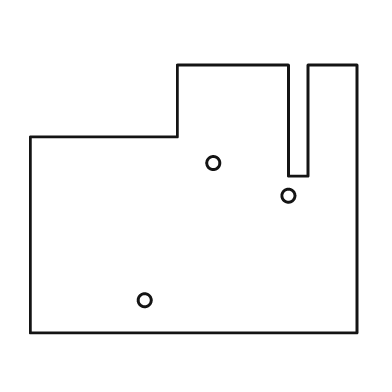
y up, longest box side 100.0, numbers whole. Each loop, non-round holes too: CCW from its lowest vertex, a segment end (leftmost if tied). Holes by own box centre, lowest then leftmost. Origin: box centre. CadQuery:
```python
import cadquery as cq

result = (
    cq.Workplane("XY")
    .moveTo(-50.0, -41.0)
    .lineTo(50.0, -41.0)
    .lineTo(50.0, 41.0)
    .lineTo(35.0, 41.0)
    .lineTo(35.0, 7.0)
    .lineTo(29.0, 7.0)
    .lineTo(29.0, 41.0)
    .lineTo(-5.0, 41.0)
    .lineTo(-5.0, 19.0)
    .lineTo(-50.0, 19.0)
    .close()
    .moveTo(-15.0, -31.0)
    .circle(2.0)
    .moveTo(29.0, 1.0)
    .circle(2.0)
    .moveTo(6.0, 11.0)
    .circle(2.0)
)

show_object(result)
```